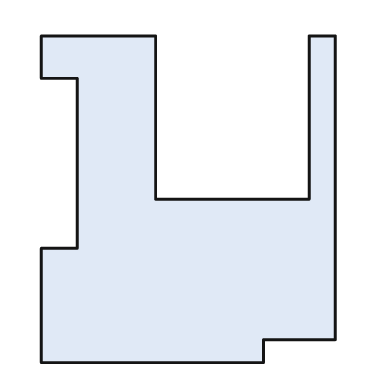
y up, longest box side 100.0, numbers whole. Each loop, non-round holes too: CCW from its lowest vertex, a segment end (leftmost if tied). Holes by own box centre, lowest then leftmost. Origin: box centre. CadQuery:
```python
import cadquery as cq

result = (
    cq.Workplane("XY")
    .moveTo(-45.0, -50.0)
    .lineTo(23.0, -50.0)
    .lineTo(23.0, -43.0)
    .lineTo(45.0, -43.0)
    .lineTo(45.0, 50.0)
    .lineTo(37.0, 50.0)
    .lineTo(37.0, 0.0)
    .lineTo(-10.0, 0.0)
    .lineTo(-10.0, 50.0)
    .lineTo(-45.0, 50.0)
    .lineTo(-45.0, 37.0)
    .lineTo(-34.0, 37.0)
    .lineTo(-34.0, -15.0)
    .lineTo(-45.0, -15.0)
    .close()
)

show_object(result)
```